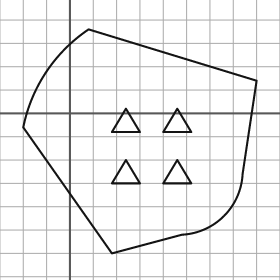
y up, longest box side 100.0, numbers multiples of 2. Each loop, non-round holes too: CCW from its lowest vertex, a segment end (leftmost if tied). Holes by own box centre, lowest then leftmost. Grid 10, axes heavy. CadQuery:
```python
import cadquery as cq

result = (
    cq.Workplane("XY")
    .moveTo(18.0, -60.0)
    .lineTo(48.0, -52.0)
    .threePointArc((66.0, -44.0), (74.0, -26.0))
    .lineTo(80.0, 14.0)
    .lineTo(8.0, 36.0)
    .threePointArc((-10.0, 18.0), (-20.0, -6.0))
    .close()
    .moveTo(18.0, -30.0)
    .lineTo(30.0, -30.0)
    .lineTo(24.0, -20.0)
    .close()
    .moveTo(40.0, -30.0)
    .lineTo(52.0, -30.0)
    .lineTo(46.0, -20.0)
    .close()
    .moveTo(18.0, -8.0)
    .lineTo(30.0, -8.0)
    .lineTo(24.0, 2.0)
    .close()
    .moveTo(40.0, -8.0)
    .lineTo(52.0, -8.0)
    .lineTo(46.0, 2.0)
    .close()
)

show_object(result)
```